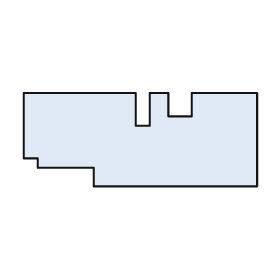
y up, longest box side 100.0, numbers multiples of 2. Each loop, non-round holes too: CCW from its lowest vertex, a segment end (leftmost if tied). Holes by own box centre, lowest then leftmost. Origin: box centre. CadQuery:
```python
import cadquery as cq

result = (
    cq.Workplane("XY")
    .moveTo(-20.0, -20.0)
    .lineTo(50.0, -20.0)
    .lineTo(50.0, 20.0)
    .lineTo(22.0, 20.0)
    .lineTo(22.0, 10.0)
    .lineTo(12.0, 10.0)
    .lineTo(12.0, 20.0)
    .lineTo(4.0, 20.0)
    .lineTo(4.0, 6.0)
    .lineTo(-2.0, 6.0)
    .lineTo(-2.0, 20.0)
    .lineTo(-50.0, 20.0)
    .lineTo(-50.0, -8.0)
    .lineTo(-44.0, -8.0)
    .lineTo(-44.0, -12.0)
    .lineTo(-20.0, -12.0)
    .close()
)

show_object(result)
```